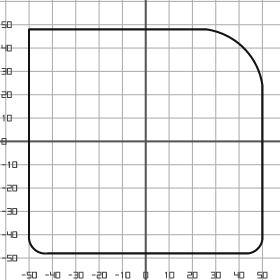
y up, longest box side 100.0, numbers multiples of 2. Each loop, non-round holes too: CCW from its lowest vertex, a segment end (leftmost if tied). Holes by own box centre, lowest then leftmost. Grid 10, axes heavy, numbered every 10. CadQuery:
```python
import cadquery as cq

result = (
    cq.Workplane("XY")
    .moveTo(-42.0, -48.0)
    .lineTo(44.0, -48.0)
    .threePointArc((48.0, -46.0), (50.0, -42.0))
    .lineTo(50.0, 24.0)
    .threePointArc((42.0, 40.0), (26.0, 48.0))
    .lineTo(-50.0, 48.0)
    .lineTo(-50.0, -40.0)
    .threePointArc((-48.0, -46.0), (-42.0, -48.0))
    .close()
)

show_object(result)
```